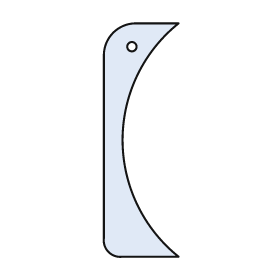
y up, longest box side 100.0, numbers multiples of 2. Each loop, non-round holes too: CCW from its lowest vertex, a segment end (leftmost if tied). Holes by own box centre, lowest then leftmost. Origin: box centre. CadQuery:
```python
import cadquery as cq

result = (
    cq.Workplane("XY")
    .moveTo(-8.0, -50.0)
    .lineTo(16.0, -50.0)
    .threePointArc((-8.0, 0.0), (16.0, 50.0))
    .lineTo(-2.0, 50.0)
    .threePointArc((-12.0, 46.0), (-16.0, 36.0))
    .lineTo(-16.0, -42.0)
    .threePointArc((-14.0, -48.0), (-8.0, -50.0))
    .close()
    .moveTo(-4.0, 40.0)
    .circle(2.0)
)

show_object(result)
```